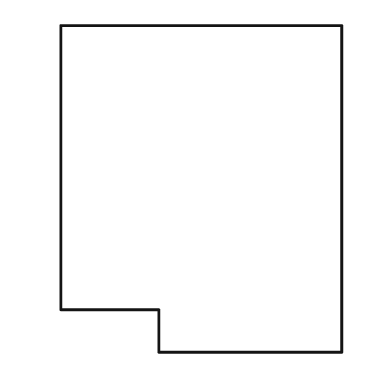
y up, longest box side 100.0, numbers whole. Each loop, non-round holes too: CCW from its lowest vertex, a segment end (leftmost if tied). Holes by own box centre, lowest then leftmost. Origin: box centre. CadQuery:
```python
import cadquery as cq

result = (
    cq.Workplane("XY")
    .moveTo(-13.0, -50.0)
    .lineTo(43.0, -50.0)
    .lineTo(43.0, 50.0)
    .lineTo(-43.0, 50.0)
    .lineTo(-43.0, -37.0)
    .lineTo(-13.0, -37.0)
    .close()
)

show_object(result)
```